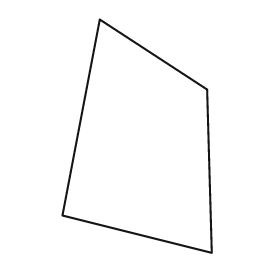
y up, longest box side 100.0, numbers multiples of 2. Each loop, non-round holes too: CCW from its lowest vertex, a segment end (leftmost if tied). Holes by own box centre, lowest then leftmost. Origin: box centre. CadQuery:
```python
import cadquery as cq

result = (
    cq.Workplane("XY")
    .moveTo(32.0, -50.0)
    .lineTo(30.0, 20.0)
    .lineTo(-16.0, 50.0)
    .lineTo(-32.0, -34.0)
    .close()
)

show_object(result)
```